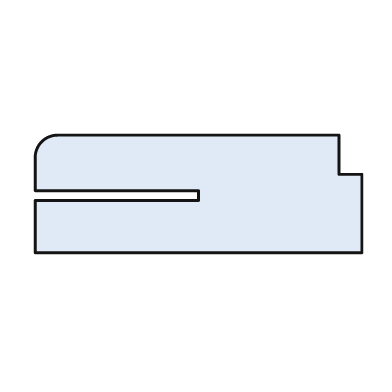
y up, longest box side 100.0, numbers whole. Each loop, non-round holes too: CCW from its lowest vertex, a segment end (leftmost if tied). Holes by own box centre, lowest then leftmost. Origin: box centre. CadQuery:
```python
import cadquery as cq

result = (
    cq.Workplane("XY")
    .moveTo(-50.0, -18.0)
    .lineTo(50.0, -18.0)
    .lineTo(50.0, 6.0)
    .lineTo(43.0, 6.0)
    .lineTo(43.0, 18.0)
    .lineTo(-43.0, 18.0)
    .threePointArc((-48.0, 16.0), (-50.0, 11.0))
    .lineTo(-50.0, 1.0)
    .lineTo(0.0, 1.0)
    .lineTo(0.0, -2.0)
    .lineTo(-50.0, -2.0)
    .close()
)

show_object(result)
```